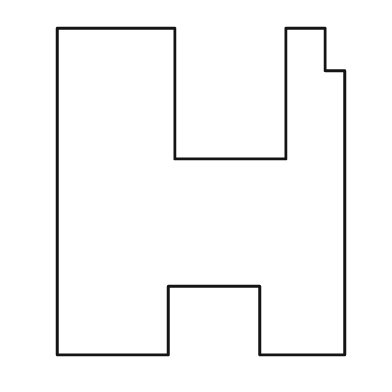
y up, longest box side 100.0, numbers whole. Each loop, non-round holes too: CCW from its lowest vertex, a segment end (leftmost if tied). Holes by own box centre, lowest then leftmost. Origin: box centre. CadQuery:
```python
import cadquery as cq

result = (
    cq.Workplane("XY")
    .moveTo(-44.0, -50.0)
    .lineTo(-10.0, -50.0)
    .lineTo(-10.0, -29.0)
    .lineTo(18.0, -29.0)
    .lineTo(18.0, -50.0)
    .lineTo(44.0, -50.0)
    .lineTo(44.0, 37.0)
    .lineTo(38.0, 37.0)
    .lineTo(38.0, 50.0)
    .lineTo(26.0, 50.0)
    .lineTo(26.0, 10.0)
    .lineTo(-8.0, 10.0)
    .lineTo(-8.0, 50.0)
    .lineTo(-44.0, 50.0)
    .close()
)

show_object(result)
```